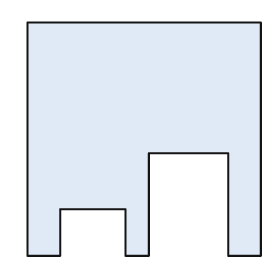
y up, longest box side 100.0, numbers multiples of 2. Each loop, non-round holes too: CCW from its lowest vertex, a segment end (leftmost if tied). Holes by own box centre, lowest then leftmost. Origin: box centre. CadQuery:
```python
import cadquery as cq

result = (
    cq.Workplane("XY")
    .moveTo(-50.0, -50.0)
    .lineTo(-36.0, -50.0)
    .lineTo(-36.0, -30.0)
    .lineTo(-8.0, -30.0)
    .lineTo(-8.0, -50.0)
    .lineTo(2.0, -50.0)
    .lineTo(2.0, -6.0)
    .lineTo(36.0, -6.0)
    .lineTo(36.0, -50.0)
    .lineTo(50.0, -50.0)
    .lineTo(50.0, 50.0)
    .lineTo(-50.0, 50.0)
    .close()
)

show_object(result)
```